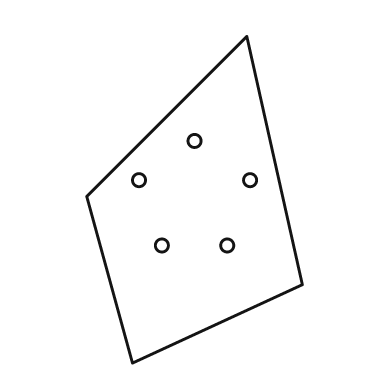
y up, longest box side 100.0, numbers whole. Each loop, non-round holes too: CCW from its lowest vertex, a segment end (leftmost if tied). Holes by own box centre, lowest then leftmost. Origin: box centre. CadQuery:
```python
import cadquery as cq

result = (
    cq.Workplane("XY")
    .moveTo(-19.0, -50.0)
    .lineTo(33.0, -26.0)
    .lineTo(16.0, 50.0)
    .lineTo(-33.0, 1.0)
    .close()
    .moveTo(-10.0, -14.0)
    .circle(2.0)
    .moveTo(10.0, -14.0)
    .circle(2.0)
    .moveTo(-17.0, 6.0)
    .circle(2.0)
    .moveTo(17.0, 6.0)
    .circle(2.0)
    .moveTo(0.0, 18.0)
    .circle(2.0)
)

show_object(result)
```